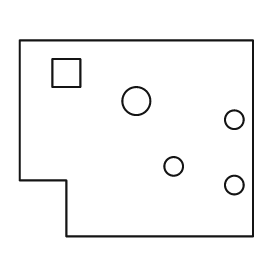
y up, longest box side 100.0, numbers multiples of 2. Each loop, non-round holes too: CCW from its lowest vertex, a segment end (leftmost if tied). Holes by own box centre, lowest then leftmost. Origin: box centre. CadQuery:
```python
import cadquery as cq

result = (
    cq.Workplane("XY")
    .moveTo(-30.0, -42.0)
    .lineTo(50.0, -42.0)
    .lineTo(50.0, 42.0)
    .lineTo(-50.0, 42.0)
    .lineTo(-50.0, -18.0)
    .lineTo(-30.0, -18.0)
    .close()
    .moveTo(42.0, -20.0)
    .circle(4.0)
    .moveTo(16.0, -12.0)
    .circle(4.0)
    .moveTo(42.0, 8.0)
    .circle(4.0)
    .moveTo(0.0, 16.0)
    .circle(6.0)
    .moveTo(-36.0, 22.0)
    .lineTo(-24.0, 22.0)
    .lineTo(-24.0, 34.0)
    .lineTo(-36.0, 34.0)
    .close()
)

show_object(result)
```